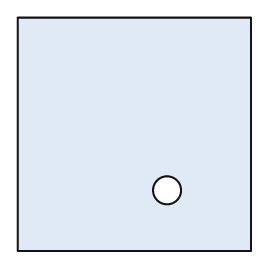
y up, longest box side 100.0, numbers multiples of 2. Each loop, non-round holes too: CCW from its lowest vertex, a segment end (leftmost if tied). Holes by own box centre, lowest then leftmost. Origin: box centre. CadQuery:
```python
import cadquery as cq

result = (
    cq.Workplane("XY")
    .moveTo(-50.0, -50.0)
    .lineTo(50.0, -50.0)
    .lineTo(50.0, 50.0)
    .lineTo(-50.0, 50.0)
    .close()
    .moveTo(14.0, -24.0)
    .circle(6.0)
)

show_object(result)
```